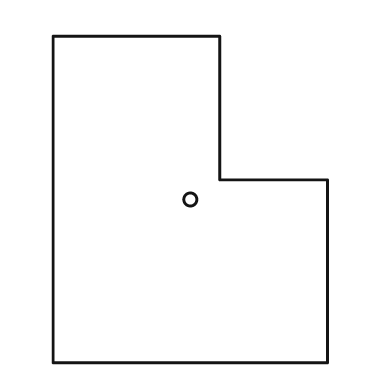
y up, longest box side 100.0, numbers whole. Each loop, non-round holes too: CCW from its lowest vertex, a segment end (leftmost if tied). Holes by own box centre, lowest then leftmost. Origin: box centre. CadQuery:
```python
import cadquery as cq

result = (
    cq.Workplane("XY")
    .moveTo(-42.0, -50.0)
    .lineTo(42.0, -50.0)
    .lineTo(42.0, 6.0)
    .lineTo(9.0, 6.0)
    .lineTo(9.0, 50.0)
    .lineTo(-42.0, 50.0)
    .close()
    .moveTo(0.0, 0.0)
    .circle(2.0)
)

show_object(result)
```